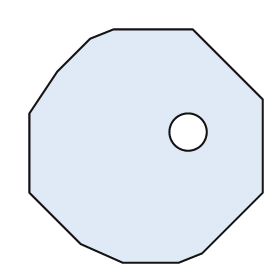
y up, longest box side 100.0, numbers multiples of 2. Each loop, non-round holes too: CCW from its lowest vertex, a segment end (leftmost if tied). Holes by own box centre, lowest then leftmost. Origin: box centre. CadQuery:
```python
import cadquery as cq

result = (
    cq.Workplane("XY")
    .moveTo(-10.0, -50.0)
    .lineTo(14.0, -50.0)
    .lineTo(24.0, -46.0)
    .lineTo(50.0, -20.0)
    .lineTo(50.0, 20.0)
    .lineTo(20.0, 50.0)
    .lineTo(-14.0, 50.0)
    .lineTo(-24.0, 46.0)
    .lineTo(-38.0, 32.0)
    .lineTo(-50.0, 14.0)
    .lineTo(-50.0, -20.0)
    .lineTo(-28.0, -42.0)
    .close()
    .moveTo(18.0, 6.0)
    .circle(8.0)
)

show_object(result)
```